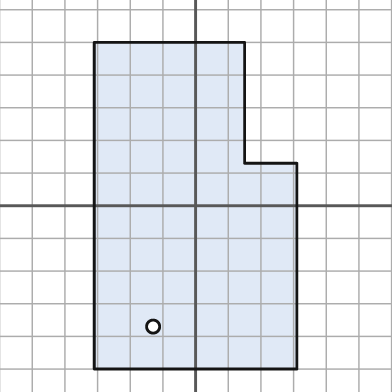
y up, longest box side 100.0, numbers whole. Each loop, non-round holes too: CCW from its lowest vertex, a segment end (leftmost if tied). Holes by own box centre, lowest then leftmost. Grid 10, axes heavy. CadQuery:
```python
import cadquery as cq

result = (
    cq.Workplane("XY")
    .moveTo(-31.0, -50.0)
    .lineTo(31.0, -50.0)
    .lineTo(31.0, 13.0)
    .lineTo(15.0, 13.0)
    .lineTo(15.0, 50.0)
    .lineTo(-31.0, 50.0)
    .close()
    .moveTo(-13.0, -37.0)
    .circle(2.0)
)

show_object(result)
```